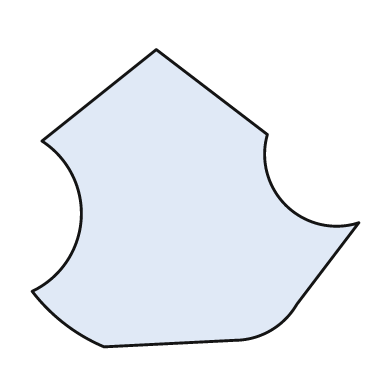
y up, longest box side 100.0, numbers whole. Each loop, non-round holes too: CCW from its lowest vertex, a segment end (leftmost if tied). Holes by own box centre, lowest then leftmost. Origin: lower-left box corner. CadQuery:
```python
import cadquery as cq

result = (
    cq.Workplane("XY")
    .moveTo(22.0, 0.0)
    .lineTo(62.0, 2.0)
    .threePointArc((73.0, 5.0), (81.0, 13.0))
    .lineTo(100.0, 38.0)
    .threePointArc((78.0, 43.0), (72.0, 65.0))
    .lineTo(38.0, 91.0)
    .lineTo(3.0, 63.0)
    .threePointArc((15.0, 39.0), (0.0, 17.0))
    .threePointArc((10.0, 7.0), (22.0, 0.0))
    .close()
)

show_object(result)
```